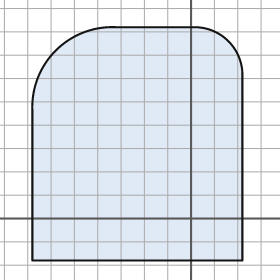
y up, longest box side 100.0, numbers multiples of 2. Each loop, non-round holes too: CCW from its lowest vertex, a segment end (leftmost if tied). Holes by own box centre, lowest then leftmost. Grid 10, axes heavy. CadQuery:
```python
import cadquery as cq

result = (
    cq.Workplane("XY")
    .moveTo(-68.0, -18.0)
    .lineTo(22.0, -18.0)
    .lineTo(22.0, 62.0)
    .threePointArc((16.0, 76.0), (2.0, 82.0))
    .lineTo(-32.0, 82.0)
    .threePointArc((-58.0, 72.0), (-68.0, 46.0))
    .close()
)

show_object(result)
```